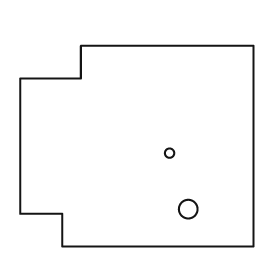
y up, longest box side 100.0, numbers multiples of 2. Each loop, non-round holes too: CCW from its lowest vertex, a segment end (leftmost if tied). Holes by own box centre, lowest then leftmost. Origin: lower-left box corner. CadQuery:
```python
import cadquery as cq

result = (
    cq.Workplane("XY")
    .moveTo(18.0, 0.0)
    .lineTo(100.0, 0.0)
    .lineTo(100.0, 86.0)
    .lineTo(26.0, 86.0)
    .lineTo(26.0, 72.0)
    .lineTo(0.0, 72.0)
    .lineTo(0.0, 14.0)
    .lineTo(18.0, 14.0)
    .close()
    .moveTo(72.0, 16.0)
    .circle(4.0)
    .moveTo(64.0, 40.0)
    .circle(2.0)
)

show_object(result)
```